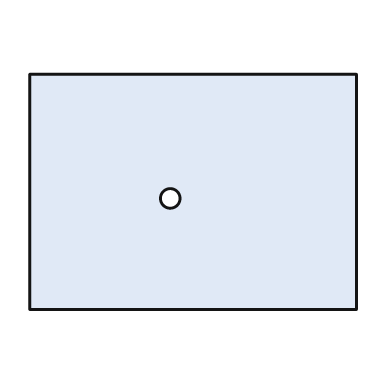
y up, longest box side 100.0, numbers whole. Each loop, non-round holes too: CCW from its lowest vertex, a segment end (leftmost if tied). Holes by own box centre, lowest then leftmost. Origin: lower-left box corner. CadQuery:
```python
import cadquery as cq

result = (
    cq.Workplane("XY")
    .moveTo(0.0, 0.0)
    .lineTo(100.0, 0.0)
    .lineTo(100.0, 72.0)
    .lineTo(0.0, 72.0)
    .close()
    .moveTo(43.0, 34.0)
    .circle(3.0)
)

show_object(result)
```